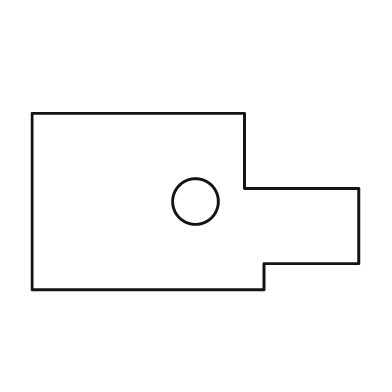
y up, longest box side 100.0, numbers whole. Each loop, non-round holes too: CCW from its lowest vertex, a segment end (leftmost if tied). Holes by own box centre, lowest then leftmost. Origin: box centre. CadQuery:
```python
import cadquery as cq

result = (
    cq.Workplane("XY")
    .moveTo(-50.0, -27.0)
    .lineTo(21.0, -27.0)
    .lineTo(21.0, -19.0)
    .lineTo(50.0, -19.0)
    .lineTo(50.0, 4.0)
    .lineTo(15.0, 4.0)
    .lineTo(15.0, 27.0)
    .lineTo(-50.0, 27.0)
    .close()
    .moveTo(0.0, 0.0)
    .circle(7.0)
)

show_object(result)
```